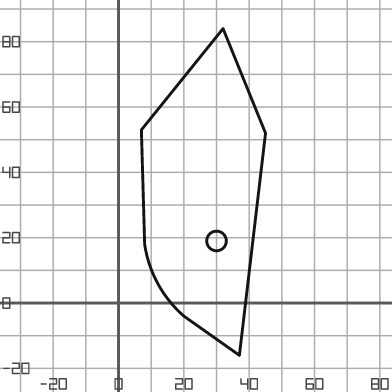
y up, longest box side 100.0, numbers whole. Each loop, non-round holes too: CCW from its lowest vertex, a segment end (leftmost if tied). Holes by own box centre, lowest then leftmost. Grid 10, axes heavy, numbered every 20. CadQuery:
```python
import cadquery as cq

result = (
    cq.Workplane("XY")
    .moveTo(37.0, -16.0)
    .lineTo(45.0, 52.0)
    .lineTo(32.0, 84.0)
    .lineTo(7.0, 53.0)
    .lineTo(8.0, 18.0)
    .threePointArc((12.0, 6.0), (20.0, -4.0))
    .close()
    .moveTo(30.0, 19.0)
    .circle(3.0)
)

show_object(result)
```